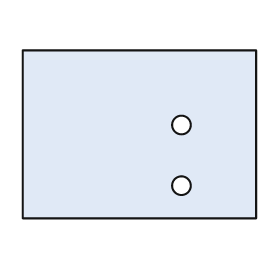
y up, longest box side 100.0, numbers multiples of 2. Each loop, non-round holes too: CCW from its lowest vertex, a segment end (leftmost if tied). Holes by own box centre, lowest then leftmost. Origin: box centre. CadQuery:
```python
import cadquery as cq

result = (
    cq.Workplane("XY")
    .moveTo(-50.0, -36.0)
    .lineTo(50.0, -36.0)
    .lineTo(50.0, 36.0)
    .lineTo(-50.0, 36.0)
    .close()
    .moveTo(18.0, -22.0)
    .circle(4.0)
    .moveTo(18.0, 4.0)
    .circle(4.0)
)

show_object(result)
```